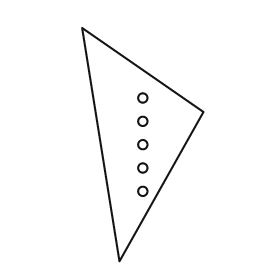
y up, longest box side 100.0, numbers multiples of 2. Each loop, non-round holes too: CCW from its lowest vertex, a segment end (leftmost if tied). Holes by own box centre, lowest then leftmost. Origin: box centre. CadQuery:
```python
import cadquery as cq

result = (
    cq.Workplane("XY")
    .moveTo(-10.0, -50.0)
    .lineTo(26.0, 14.0)
    .lineTo(-26.0, 50.0)
    .close()
    .moveTo(0.0, -20.0)
    .circle(2.0)
    .moveTo(0.0, -10.0)
    .circle(2.0)
    .moveTo(0.0, 0.0)
    .circle(2.0)
    .moveTo(0.0, 10.0)
    .circle(2.0)
    .moveTo(0.0, 20.0)
    .circle(2.0)
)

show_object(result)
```